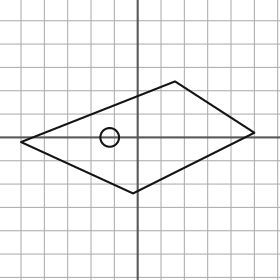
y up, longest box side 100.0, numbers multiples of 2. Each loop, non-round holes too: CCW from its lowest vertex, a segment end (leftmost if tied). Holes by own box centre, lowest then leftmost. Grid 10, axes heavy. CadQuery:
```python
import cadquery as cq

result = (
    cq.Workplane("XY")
    .moveTo(-2.0, -24.0)
    .lineTo(50.0, 2.0)
    .lineTo(16.0, 24.0)
    .lineTo(-50.0, -2.0)
    .close()
    .moveTo(-12.0, 0.0)
    .circle(4.0)
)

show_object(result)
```